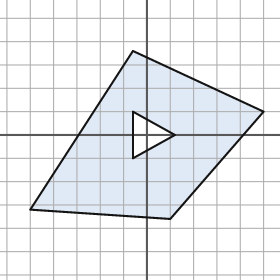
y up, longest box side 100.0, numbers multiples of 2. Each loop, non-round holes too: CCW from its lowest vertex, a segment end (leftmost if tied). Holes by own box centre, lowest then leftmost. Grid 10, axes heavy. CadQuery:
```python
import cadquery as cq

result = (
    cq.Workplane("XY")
    .moveTo(10.0, -36.0)
    .lineTo(50.0, 10.0)
    .lineTo(-6.0, 36.0)
    .lineTo(-50.0, -32.0)
    .close()
    .moveTo(-6.0, -10.0)
    .lineTo(12.0, 0.0)
    .lineTo(-6.0, 10.0)
    .close()
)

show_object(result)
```